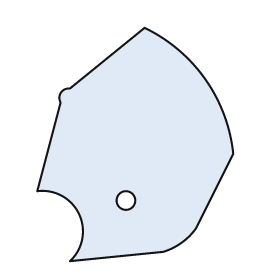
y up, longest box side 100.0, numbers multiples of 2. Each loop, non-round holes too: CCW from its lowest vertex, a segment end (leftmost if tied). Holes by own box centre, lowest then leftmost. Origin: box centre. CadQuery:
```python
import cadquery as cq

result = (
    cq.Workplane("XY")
    .moveTo(-28.0, -50.0)
    .lineTo(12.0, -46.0)
    .threePointArc((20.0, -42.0), (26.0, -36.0))
    .lineTo(42.0, -4.0)
    .threePointArc((30.0, 28.0), (4.0, 50.0))
    .lineTo(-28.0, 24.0)
    .threePointArc((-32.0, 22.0), (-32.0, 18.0))
    .lineTo(-42.0, -20.0)
    .threePointArc((-24.0, -30.0), (-28.0, -50.0))
    .close()
    .moveTo(-4.0, -24.0)
    .circle(4.0)
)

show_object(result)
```